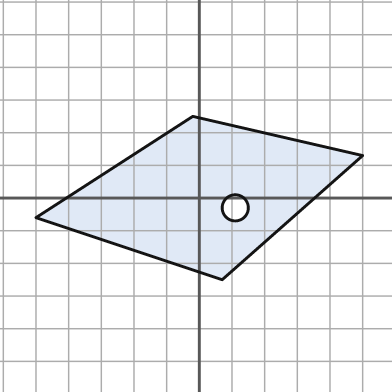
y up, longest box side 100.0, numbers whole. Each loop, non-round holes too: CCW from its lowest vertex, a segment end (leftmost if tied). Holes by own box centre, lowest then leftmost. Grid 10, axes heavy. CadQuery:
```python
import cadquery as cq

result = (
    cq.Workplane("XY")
    .moveTo(7.0, -25.0)
    .lineTo(50.0, 13.0)
    .lineTo(-2.0, 25.0)
    .lineTo(-50.0, -6.0)
    .close()
    .moveTo(11.0, -3.0)
    .circle(4.0)
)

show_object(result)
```